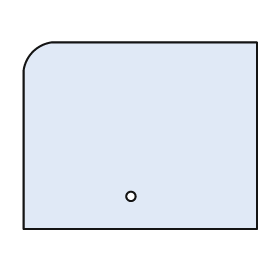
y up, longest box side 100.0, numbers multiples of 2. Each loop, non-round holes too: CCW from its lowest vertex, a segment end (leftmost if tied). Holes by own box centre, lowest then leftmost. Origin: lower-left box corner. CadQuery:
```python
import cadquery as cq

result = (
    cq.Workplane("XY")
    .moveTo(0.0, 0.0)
    .lineTo(100.0, 0.0)
    .lineTo(100.0, 80.0)
    .lineTo(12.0, 80.0)
    .threePointArc((4.0, 76.0), (0.0, 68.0))
    .close()
    .moveTo(46.0, 14.0)
    .circle(2.0)
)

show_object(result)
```